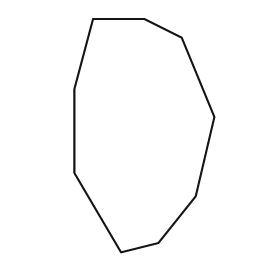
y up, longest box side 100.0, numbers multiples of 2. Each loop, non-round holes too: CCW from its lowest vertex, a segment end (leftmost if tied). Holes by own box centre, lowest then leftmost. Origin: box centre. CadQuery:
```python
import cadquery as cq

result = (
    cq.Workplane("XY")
    .moveTo(-10.0, -50.0)
    .lineTo(6.0, -46.0)
    .lineTo(22.0, -26.0)
    .lineTo(30.0, 8.0)
    .lineTo(16.0, 42.0)
    .lineTo(0.0, 50.0)
    .lineTo(-22.0, 50.0)
    .lineTo(-30.0, 20.0)
    .lineTo(-30.0, -16.0)
    .close()
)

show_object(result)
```